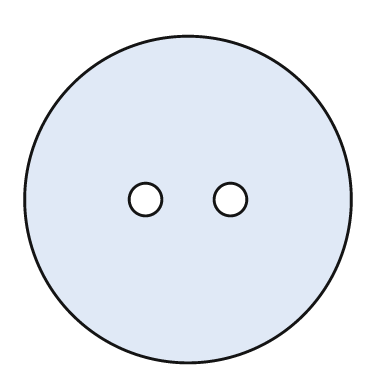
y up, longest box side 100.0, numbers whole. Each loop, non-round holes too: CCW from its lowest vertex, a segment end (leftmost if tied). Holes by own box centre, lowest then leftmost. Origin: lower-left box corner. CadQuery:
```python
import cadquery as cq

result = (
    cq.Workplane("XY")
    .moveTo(50.0, 50.0)
    .circle(50.0)
    .moveTo(37.0, 50.0)
    .circle(5.0)
    .moveTo(63.0, 50.0)
    .circle(5.0)
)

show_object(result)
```